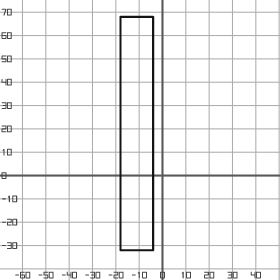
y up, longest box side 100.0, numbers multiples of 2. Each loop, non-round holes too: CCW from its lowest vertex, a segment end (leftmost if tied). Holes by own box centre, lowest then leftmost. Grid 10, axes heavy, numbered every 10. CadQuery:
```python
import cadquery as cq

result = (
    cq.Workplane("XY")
    .moveTo(-18.0, -32.0)
    .lineTo(-4.0, -32.0)
    .lineTo(-4.0, 68.0)
    .lineTo(-18.0, 68.0)
    .close()
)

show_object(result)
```